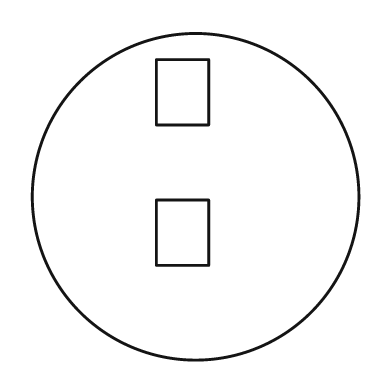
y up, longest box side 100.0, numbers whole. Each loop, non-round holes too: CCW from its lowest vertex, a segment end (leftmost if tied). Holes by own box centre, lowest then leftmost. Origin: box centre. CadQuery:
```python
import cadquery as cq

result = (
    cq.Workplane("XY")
    .moveTo(0.0, 0.0)
    .circle(50.0)
    .moveTo(-12.0, -21.0)
    .lineTo(4.0, -21.0)
    .lineTo(4.0, -1.0)
    .lineTo(-12.0, -1.0)
    .close()
    .moveTo(-12.0, 22.0)
    .lineTo(4.0, 22.0)
    .lineTo(4.0, 42.0)
    .lineTo(-12.0, 42.0)
    .close()
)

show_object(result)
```